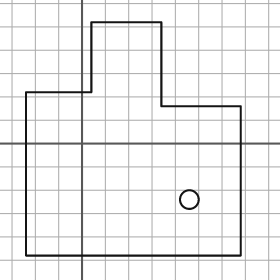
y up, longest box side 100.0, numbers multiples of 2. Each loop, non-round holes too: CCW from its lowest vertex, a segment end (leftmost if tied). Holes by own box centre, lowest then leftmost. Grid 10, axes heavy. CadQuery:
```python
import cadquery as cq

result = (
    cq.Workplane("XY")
    .moveTo(-24.0, -48.0)
    .lineTo(68.0, -48.0)
    .lineTo(68.0, 16.0)
    .lineTo(34.0, 16.0)
    .lineTo(34.0, 52.0)
    .lineTo(4.0, 52.0)
    .lineTo(4.0, 22.0)
    .lineTo(-24.0, 22.0)
    .close()
    .moveTo(46.0, -24.0)
    .circle(4.0)
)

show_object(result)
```